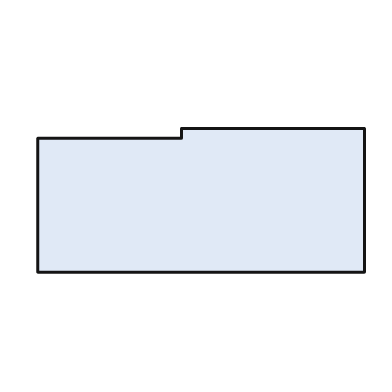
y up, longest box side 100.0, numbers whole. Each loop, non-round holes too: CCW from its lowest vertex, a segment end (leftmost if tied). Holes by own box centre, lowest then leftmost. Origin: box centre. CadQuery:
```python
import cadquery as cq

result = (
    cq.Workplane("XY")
    .moveTo(-50.0, -22.0)
    .lineTo(50.0, -22.0)
    .lineTo(50.0, 22.0)
    .lineTo(-6.0, 22.0)
    .lineTo(-6.0, 19.0)
    .lineTo(-50.0, 19.0)
    .close()
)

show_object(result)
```